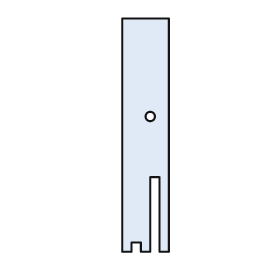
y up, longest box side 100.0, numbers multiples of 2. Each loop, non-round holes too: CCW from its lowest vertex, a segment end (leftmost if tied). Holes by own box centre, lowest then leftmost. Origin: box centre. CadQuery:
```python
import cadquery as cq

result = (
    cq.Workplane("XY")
    .moveTo(-10.0, -50.0)
    .lineTo(-6.0, -50.0)
    .lineTo(-6.0, -46.0)
    .lineTo(-2.0, -46.0)
    .lineTo(-2.0, -50.0)
    .lineTo(2.0, -50.0)
    .lineTo(2.0, -18.0)
    .lineTo(6.0, -18.0)
    .lineTo(6.0, -50.0)
    .lineTo(10.0, -50.0)
    .lineTo(10.0, 50.0)
    .lineTo(-10.0, 50.0)
    .close()
    .moveTo(2.0, 8.0)
    .circle(2.0)
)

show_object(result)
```